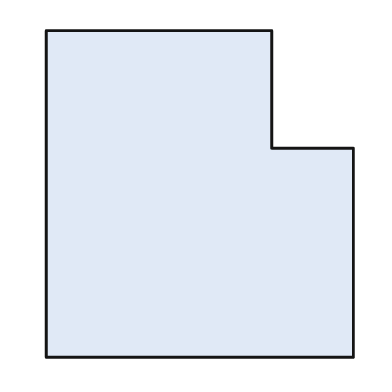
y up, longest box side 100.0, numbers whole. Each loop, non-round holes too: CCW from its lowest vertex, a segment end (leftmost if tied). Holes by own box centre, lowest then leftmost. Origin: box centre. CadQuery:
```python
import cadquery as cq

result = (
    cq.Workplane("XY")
    .moveTo(-47.0, -50.0)
    .lineTo(47.0, -50.0)
    .lineTo(47.0, 14.0)
    .lineTo(22.0, 14.0)
    .lineTo(22.0, 50.0)
    .lineTo(-47.0, 50.0)
    .close()
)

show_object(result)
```